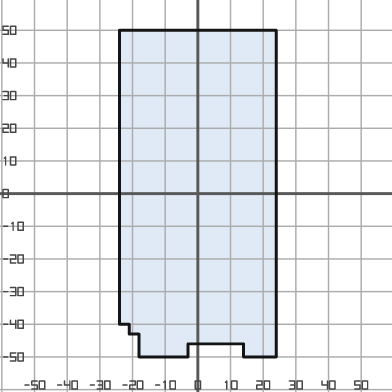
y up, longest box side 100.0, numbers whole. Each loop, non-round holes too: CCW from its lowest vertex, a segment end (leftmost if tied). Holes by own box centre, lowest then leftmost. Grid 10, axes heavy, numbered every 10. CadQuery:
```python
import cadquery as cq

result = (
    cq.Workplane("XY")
    .moveTo(-18.0, -50.0)
    .lineTo(-3.0, -50.0)
    .lineTo(-3.0, -46.0)
    .lineTo(14.0, -46.0)
    .lineTo(14.0, -50.0)
    .lineTo(24.0, -50.0)
    .lineTo(24.0, 50.0)
    .lineTo(-24.0, 50.0)
    .lineTo(-24.0, -40.0)
    .lineTo(-21.0, -40.0)
    .lineTo(-21.0, -43.0)
    .lineTo(-18.0, -43.0)
    .close()
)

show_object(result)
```